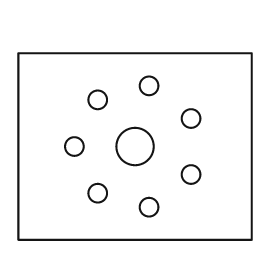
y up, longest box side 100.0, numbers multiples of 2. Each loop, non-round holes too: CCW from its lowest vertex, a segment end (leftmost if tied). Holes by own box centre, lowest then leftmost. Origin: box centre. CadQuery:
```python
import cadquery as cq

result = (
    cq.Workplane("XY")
    .moveTo(-50.0, -40.0)
    .lineTo(50.0, -40.0)
    .lineTo(50.0, 40.0)
    .lineTo(-50.0, 40.0)
    .close()
    .moveTo(6.0, -26.0)
    .circle(4.0)
    .moveTo(-16.0, -20.0)
    .circle(4.0)
    .moveTo(24.0, -12.0)
    .circle(4.0)
    .moveTo(-26.0, 0.0)
    .circle(4.0)
    .moveTo(0.0, 0.0)
    .circle(8.0)
    .moveTo(24.0, 12.0)
    .circle(4.0)
    .moveTo(-16.0, 20.0)
    .circle(4.0)
    .moveTo(6.0, 26.0)
    .circle(4.0)
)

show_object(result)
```